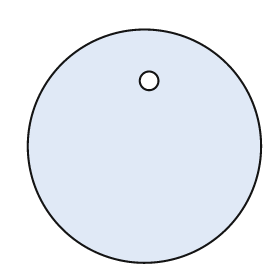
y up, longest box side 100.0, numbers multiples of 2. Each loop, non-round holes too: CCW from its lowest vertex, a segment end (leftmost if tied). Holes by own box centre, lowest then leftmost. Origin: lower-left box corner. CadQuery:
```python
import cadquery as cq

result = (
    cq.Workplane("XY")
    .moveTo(50.0, 50.0)
    .circle(50.0)
    .moveTo(52.0, 78.0)
    .circle(4.0)
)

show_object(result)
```